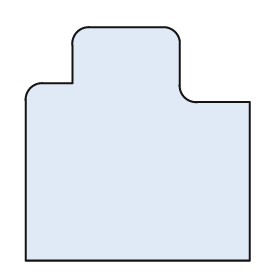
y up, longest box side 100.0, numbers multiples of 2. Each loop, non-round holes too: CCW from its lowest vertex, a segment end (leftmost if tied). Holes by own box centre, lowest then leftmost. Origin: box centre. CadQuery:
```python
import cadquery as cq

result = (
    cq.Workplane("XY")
    .moveTo(-48.0, -50.0)
    .lineTo(48.0, -50.0)
    .lineTo(48.0, 18.0)
    .lineTo(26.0, 18.0)
    .threePointArc((20.0, 20.0), (18.0, 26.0))
    .lineTo(18.0, 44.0)
    .threePointArc((16.0, 48.0), (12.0, 50.0))
    .lineTo(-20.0, 50.0)
    .threePointArc((-26.0, 48.0), (-28.0, 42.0))
    .lineTo(-28.0, 26.0)
    .lineTo(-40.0, 26.0)
    .threePointArc((-46.0, 24.0), (-48.0, 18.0))
    .close()
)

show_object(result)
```